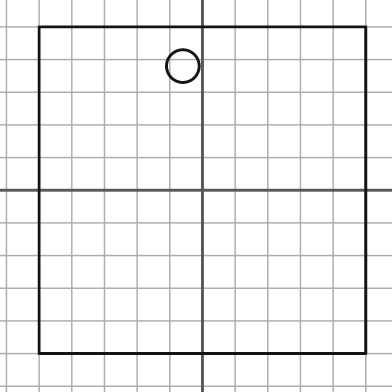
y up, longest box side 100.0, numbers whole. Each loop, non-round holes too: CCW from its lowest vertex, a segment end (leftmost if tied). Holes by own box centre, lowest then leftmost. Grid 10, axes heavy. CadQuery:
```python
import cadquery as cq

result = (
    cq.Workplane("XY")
    .moveTo(-50.0, -50.0)
    .lineTo(50.0, -50.0)
    .lineTo(50.0, 50.0)
    .lineTo(-50.0, 50.0)
    .close()
    .moveTo(-6.0, 38.0)
    .circle(5.0)
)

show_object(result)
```